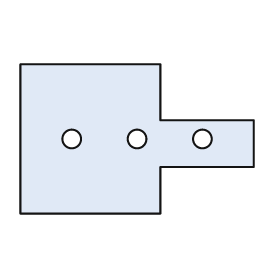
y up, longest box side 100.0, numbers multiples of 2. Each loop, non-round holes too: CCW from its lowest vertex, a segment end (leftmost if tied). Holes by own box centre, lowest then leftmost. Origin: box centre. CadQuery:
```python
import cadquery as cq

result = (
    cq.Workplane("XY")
    .moveTo(-50.0, -32.0)
    .lineTo(10.0, -32.0)
    .lineTo(10.0, -12.0)
    .lineTo(50.0, -12.0)
    .lineTo(50.0, 8.0)
    .lineTo(10.0, 8.0)
    .lineTo(10.0, 32.0)
    .lineTo(-50.0, 32.0)
    .close()
    .moveTo(-28.0, 0.0)
    .circle(4.0)
    .moveTo(0.0, 0.0)
    .circle(4.0)
    .moveTo(28.0, 0.0)
    .circle(4.0)
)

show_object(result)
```